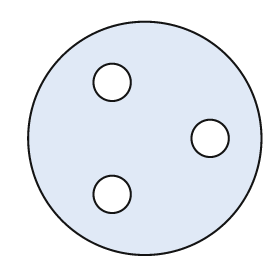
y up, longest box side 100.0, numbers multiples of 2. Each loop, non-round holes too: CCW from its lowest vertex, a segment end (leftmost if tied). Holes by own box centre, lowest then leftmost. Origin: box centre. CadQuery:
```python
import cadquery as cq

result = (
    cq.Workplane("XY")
    .moveTo(0.0, 0.0)
    .circle(50.0)
    .moveTo(-14.0, -24.0)
    .circle(8.0)
    .moveTo(28.0, 0.0)
    .circle(8.0)
    .moveTo(-14.0, 24.0)
    .circle(8.0)
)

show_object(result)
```